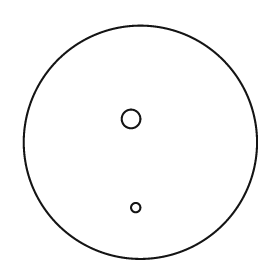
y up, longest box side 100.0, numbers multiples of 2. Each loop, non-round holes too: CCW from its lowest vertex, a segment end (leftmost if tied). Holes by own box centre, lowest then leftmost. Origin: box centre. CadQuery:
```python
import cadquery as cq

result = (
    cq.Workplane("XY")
    .moveTo(0.0, 0.0)
    .circle(50.0)
    .moveTo(-2.0, -28.0)
    .circle(2.0)
    .moveTo(-4.0, 10.0)
    .circle(4.0)
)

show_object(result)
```